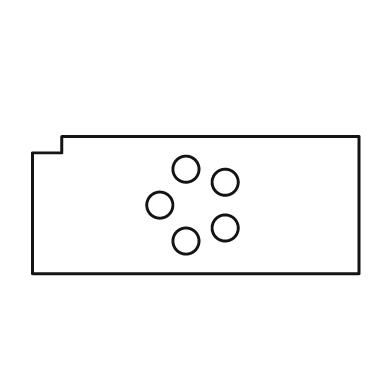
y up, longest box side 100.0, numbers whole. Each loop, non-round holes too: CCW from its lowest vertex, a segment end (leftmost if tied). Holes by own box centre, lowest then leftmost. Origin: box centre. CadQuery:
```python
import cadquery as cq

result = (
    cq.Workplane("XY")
    .moveTo(-50.0, -21.0)
    .lineTo(50.0, -21.0)
    .lineTo(50.0, 21.0)
    .lineTo(-41.0, 21.0)
    .lineTo(-41.0, 16.0)
    .lineTo(-50.0, 16.0)
    .close()
    .moveTo(-3.0, -11.0)
    .circle(4.0)
    .moveTo(9.0, -7.0)
    .circle(4.0)
    .moveTo(-11.0, 0.0)
    .circle(4.0)
    .moveTo(9.0, 7.0)
    .circle(4.0)
    .moveTo(-3.0, 11.0)
    .circle(4.0)
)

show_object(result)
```